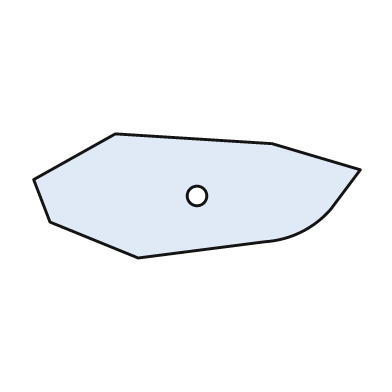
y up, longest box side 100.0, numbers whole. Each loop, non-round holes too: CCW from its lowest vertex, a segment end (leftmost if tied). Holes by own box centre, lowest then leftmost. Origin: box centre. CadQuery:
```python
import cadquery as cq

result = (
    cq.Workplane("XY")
    .moveTo(-18.0, -19.0)
    .lineTo(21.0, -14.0)
    .threePointArc((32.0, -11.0), (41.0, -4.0))
    .lineTo(50.0, 8.0)
    .lineTo(23.0, 16.0)
    .lineTo(-25.0, 19.0)
    .lineTo(-50.0, 5.0)
    .lineTo(-45.0, -8.0)
    .close()
    .moveTo(0.0, 0.0)
    .circle(3.0)
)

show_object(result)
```